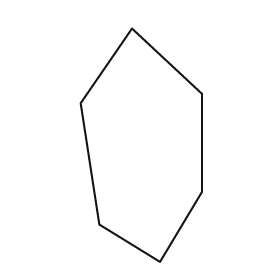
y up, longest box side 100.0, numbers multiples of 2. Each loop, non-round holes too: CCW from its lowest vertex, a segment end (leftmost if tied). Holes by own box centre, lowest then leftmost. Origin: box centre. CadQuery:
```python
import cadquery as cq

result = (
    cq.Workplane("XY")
    .moveTo(8.0, -50.0)
    .lineTo(26.0, -20.0)
    .lineTo(26.0, 22.0)
    .lineTo(-4.0, 50.0)
    .lineTo(-26.0, 18.0)
    .lineTo(-18.0, -34.0)
    .close()
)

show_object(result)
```